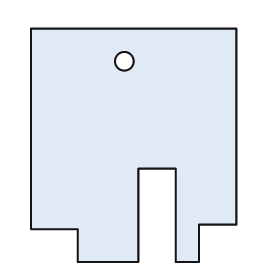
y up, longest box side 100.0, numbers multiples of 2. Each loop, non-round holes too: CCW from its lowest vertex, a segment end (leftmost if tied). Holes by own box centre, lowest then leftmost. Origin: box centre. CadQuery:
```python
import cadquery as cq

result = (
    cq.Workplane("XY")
    .moveTo(-24.0, -50.0)
    .lineTo(2.0, -50.0)
    .lineTo(2.0, -10.0)
    .lineTo(18.0, -10.0)
    .lineTo(18.0, -50.0)
    .lineTo(28.0, -50.0)
    .lineTo(28.0, -34.0)
    .lineTo(44.0, -34.0)
    .lineTo(44.0, 50.0)
    .lineTo(-44.0, 50.0)
    .lineTo(-44.0, -36.0)
    .lineTo(-24.0, -36.0)
    .close()
    .moveTo(-4.0, 36.0)
    .circle(4.0)
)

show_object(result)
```